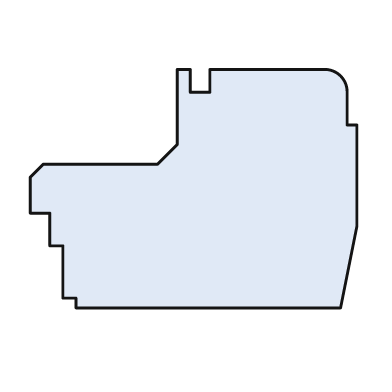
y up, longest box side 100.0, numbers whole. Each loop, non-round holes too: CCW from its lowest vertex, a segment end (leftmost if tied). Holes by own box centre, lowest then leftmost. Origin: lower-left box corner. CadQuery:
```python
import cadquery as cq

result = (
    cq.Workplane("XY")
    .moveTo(14.0, 0.0)
    .lineTo(95.0, 0.0)
    .lineTo(100.0, 25.0)
    .lineTo(100.0, 56.0)
    .lineTo(97.0, 56.0)
    .lineTo(97.0, 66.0)
    .threePointArc((95.0, 71.0), (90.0, 73.0))
    .lineTo(55.0, 73.0)
    .lineTo(55.0, 66.0)
    .lineTo(49.0, 66.0)
    .lineTo(49.0, 73.0)
    .lineTo(45.0, 73.0)
    .lineTo(45.0, 50.0)
    .lineTo(39.0, 44.0)
    .lineTo(4.0, 44.0)
    .lineTo(0.0, 40.0)
    .lineTo(0.0, 29.0)
    .lineTo(6.0, 29.0)
    .lineTo(6.0, 19.0)
    .lineTo(10.0, 19.0)
    .lineTo(10.0, 3.0)
    .lineTo(14.0, 3.0)
    .close()
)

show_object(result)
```